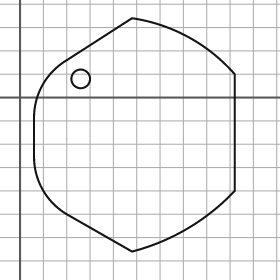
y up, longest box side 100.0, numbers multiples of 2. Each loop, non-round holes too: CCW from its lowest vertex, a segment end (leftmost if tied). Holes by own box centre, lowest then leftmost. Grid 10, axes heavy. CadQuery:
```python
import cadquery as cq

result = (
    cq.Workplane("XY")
    .moveTo(48.0, -66.0)
    .threePointArc((72.0, -56.0), (92.0, -40.0))
    .lineTo(92.0, 10.0)
    .threePointArc((72.0, 26.0), (48.0, 34.0))
    .lineTo(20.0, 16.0)
    .threePointArc((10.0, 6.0), (6.0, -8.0))
    .lineTo(6.0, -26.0)
    .threePointArc((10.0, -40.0), (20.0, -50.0))
    .close()
    .moveTo(26.0, 8.0)
    .circle(4.0)
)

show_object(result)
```